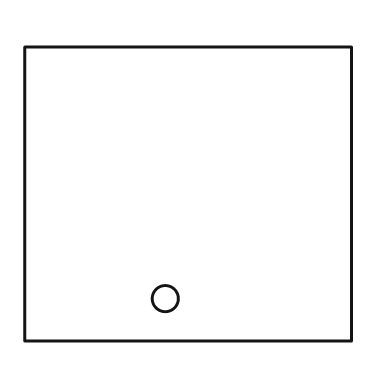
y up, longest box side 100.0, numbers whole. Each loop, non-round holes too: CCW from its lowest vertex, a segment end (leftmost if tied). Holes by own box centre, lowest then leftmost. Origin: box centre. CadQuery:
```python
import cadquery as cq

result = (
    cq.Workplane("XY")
    .moveTo(-50.0, -45.0)
    .lineTo(50.0, -45.0)
    .lineTo(50.0, 45.0)
    .lineTo(-50.0, 45.0)
    .close()
    .moveTo(-7.0, -32.0)
    .circle(4.0)
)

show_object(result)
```